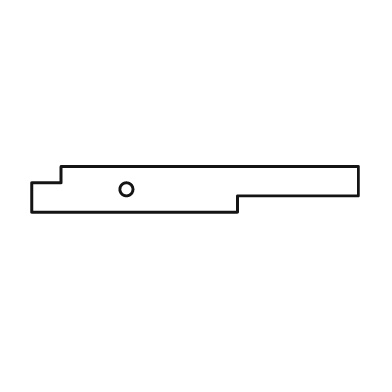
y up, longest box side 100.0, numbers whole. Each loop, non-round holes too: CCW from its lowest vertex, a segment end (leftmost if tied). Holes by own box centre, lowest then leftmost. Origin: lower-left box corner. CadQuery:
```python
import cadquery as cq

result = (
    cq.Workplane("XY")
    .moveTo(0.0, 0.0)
    .lineTo(63.0, 0.0)
    .lineTo(63.0, 5.0)
    .lineTo(100.0, 5.0)
    .lineTo(100.0, 14.0)
    .lineTo(9.0, 14.0)
    .lineTo(9.0, 9.0)
    .lineTo(0.0, 9.0)
    .close()
    .moveTo(29.0, 7.0)
    .circle(2.0)
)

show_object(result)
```